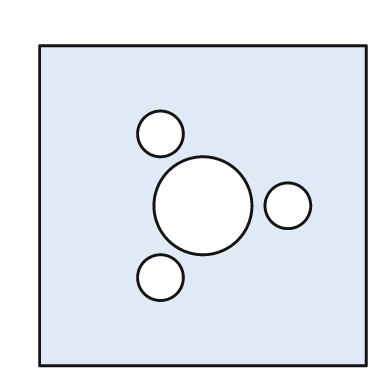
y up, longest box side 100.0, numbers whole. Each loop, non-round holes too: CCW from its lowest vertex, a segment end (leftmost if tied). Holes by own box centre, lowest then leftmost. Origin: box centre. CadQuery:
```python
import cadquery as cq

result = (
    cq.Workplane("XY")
    .moveTo(-50.0, -49.0)
    .lineTo(50.0, -49.0)
    .lineTo(50.0, 49.0)
    .lineTo(-50.0, 49.0)
    .close()
    .moveTo(-13.0, -22.0)
    .circle(7.0)
    .moveTo(0.0, 0.0)
    .circle(15.0)
    .moveTo(26.0, 0.0)
    .circle(7.0)
    .moveTo(-13.0, 22.0)
    .circle(7.0)
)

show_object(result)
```